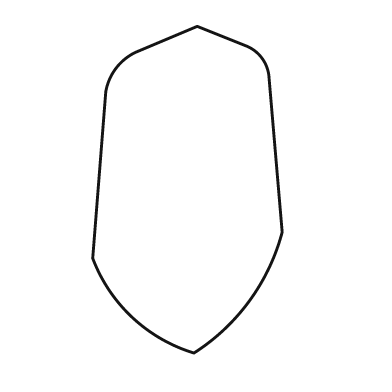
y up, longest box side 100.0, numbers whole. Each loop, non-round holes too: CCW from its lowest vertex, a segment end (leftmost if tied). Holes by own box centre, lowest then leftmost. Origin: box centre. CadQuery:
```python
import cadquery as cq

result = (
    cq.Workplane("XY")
    .moveTo(2.0, -50.0)
    .threePointArc((19.0, -34.0), (29.0, -13.0))
    .lineTo(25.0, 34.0)
    .threePointArc((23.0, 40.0), (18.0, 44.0))
    .lineTo(3.0, 50.0)
    .lineTo(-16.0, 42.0)
    .threePointArc((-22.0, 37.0), (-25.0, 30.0))
    .lineTo(-29.0, -21.0)
    .threePointArc((-17.0, -39.0), (2.0, -50.0))
    .close()
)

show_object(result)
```